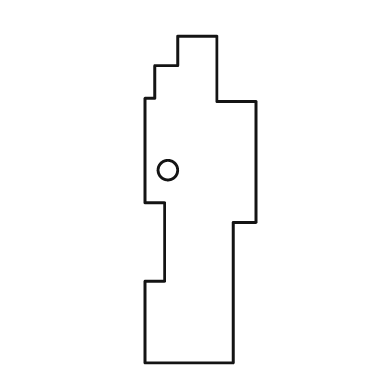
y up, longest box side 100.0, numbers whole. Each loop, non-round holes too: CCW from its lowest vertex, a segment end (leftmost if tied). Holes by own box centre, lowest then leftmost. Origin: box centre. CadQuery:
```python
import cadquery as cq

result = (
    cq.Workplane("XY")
    .moveTo(-17.0, -50.0)
    .lineTo(10.0, -50.0)
    .lineTo(10.0, -7.0)
    .lineTo(17.0, -7.0)
    .lineTo(17.0, 30.0)
    .lineTo(5.0, 30.0)
    .lineTo(5.0, 50.0)
    .lineTo(-7.0, 50.0)
    .lineTo(-7.0, 41.0)
    .lineTo(-14.0, 41.0)
    .lineTo(-14.0, 31.0)
    .lineTo(-17.0, 31.0)
    .lineTo(-17.0, -1.0)
    .lineTo(-11.0, -1.0)
    .lineTo(-11.0, -25.0)
    .lineTo(-17.0, -25.0)
    .close()
    .moveTo(-10.0, 9.0)
    .circle(3.0)
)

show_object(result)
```